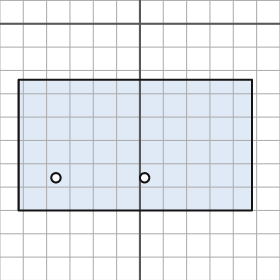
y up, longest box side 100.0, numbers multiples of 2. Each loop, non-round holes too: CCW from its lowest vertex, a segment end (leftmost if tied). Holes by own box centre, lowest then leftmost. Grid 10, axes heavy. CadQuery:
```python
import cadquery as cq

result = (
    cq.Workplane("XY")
    .moveTo(-52.0, -80.0)
    .lineTo(48.0, -80.0)
    .lineTo(48.0, -24.0)
    .lineTo(-52.0, -24.0)
    .close()
    .moveTo(-36.0, -66.0)
    .circle(2.0)
    .moveTo(2.0, -66.0)
    .circle(2.0)
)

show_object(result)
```